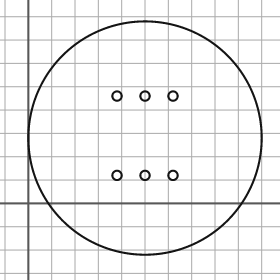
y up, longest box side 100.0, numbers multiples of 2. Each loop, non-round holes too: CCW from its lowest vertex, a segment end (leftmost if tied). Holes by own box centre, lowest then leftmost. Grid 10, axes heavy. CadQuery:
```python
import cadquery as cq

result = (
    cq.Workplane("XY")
    .moveTo(50.0, 28.0)
    .circle(50.0)
    .moveTo(38.0, 12.0)
    .circle(2.0)
    .moveTo(50.0, 12.0)
    .circle(2.0)
    .moveTo(62.0, 12.0)
    .circle(2.0)
    .moveTo(38.0, 46.0)
    .circle(2.0)
    .moveTo(50.0, 46.0)
    .circle(2.0)
    .moveTo(62.0, 46.0)
    .circle(2.0)
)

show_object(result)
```